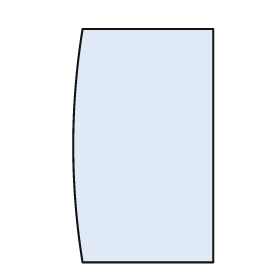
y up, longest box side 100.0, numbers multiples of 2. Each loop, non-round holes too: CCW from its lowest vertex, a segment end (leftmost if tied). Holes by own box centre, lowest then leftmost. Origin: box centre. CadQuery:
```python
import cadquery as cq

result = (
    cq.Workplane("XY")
    .moveTo(-26.0, -50.0)
    .lineTo(30.0, -50.0)
    .lineTo(30.0, 50.0)
    .lineTo(-26.0, 50.0)
    .threePointArc((-30.0, 0.0), (-26.0, -50.0))
    .close()
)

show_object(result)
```